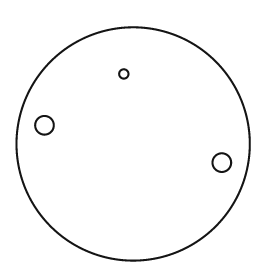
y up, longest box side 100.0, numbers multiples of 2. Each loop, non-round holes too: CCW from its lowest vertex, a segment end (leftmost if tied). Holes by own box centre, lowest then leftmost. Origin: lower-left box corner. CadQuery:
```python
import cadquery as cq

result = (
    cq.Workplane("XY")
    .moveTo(50.0, 50.0)
    .circle(50.0)
    .moveTo(88.0, 42.0)
    .circle(4.0)
    .moveTo(12.0, 58.0)
    .circle(4.0)
    .moveTo(46.0, 80.0)
    .circle(2.0)
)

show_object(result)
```